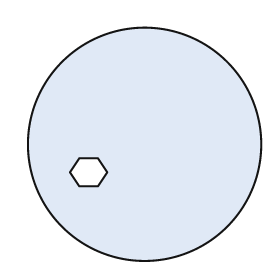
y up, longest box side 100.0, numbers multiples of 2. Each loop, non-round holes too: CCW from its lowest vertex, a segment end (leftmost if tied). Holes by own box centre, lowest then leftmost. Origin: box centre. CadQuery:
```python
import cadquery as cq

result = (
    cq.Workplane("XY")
    .moveTo(0.0, 0.0)
    .circle(50.0)
    .moveTo(-28.0, -18.0)
    .lineTo(-20.0, -18.0)
    .lineTo(-16.0, -12.0)
    .lineTo(-20.0, -6.0)
    .lineTo(-28.0, -6.0)
    .lineTo(-32.0, -12.0)
    .close()
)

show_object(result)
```